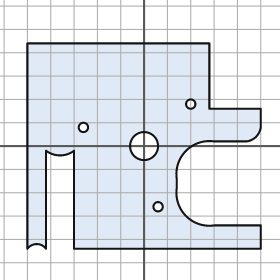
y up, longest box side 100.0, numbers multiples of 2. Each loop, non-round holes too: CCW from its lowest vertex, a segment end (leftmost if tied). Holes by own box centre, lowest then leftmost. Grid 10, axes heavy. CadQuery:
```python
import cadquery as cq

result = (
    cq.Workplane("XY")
    .moveTo(-50.0, -44.0)
    .threePointArc((-46.0, -42.0), (-42.0, -44.0))
    .lineTo(-42.0, -2.0)
    .threePointArc((-36.0, -4.0), (-30.0, -2.0))
    .lineTo(-30.0, -44.0)
    .lineTo(50.0, -44.0)
    .lineTo(50.0, -34.0)
    .lineTo(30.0, -34.0)
    .threePointArc((18.0, -30.0), (14.0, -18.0))
    .lineTo(14.0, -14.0)
    .threePointArc((18.0, -2.0), (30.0, 2.0))
    .lineTo(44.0, 2.0)
    .threePointArc((48.0, 4.0), (50.0, 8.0))
    .lineTo(50.0, 16.0)
    .lineTo(28.0, 16.0)
    .lineTo(28.0, 44.0)
    .lineTo(-50.0, 44.0)
    .close()
    .moveTo(6.0, -26.0)
    .circle(2.0)
    .moveTo(0.0, 0.0)
    .circle(6.0)
    .moveTo(-26.0, 8.0)
    .circle(2.0)
    .moveTo(20.0, 18.0)
    .circle(2.0)
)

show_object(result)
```